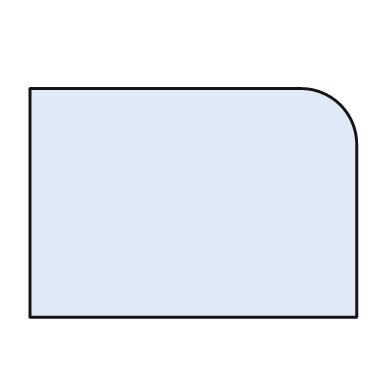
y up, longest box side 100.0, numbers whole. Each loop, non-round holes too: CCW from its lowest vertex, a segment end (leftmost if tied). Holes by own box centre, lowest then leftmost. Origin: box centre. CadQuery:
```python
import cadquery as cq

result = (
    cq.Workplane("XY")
    .moveTo(-50.0, -35.0)
    .lineTo(50.0, -35.0)
    .lineTo(50.0, 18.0)
    .threePointArc((45.0, 30.0), (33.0, 35.0))
    .lineTo(-50.0, 35.0)
    .close()
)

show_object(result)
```